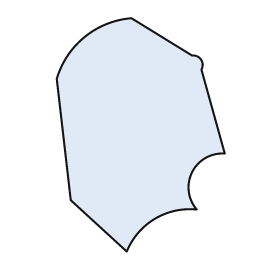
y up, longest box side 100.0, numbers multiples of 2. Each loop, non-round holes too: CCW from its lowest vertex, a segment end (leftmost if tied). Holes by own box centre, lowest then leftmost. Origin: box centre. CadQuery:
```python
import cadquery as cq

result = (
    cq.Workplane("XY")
    .moveTo(-6.0, -50.0)
    .threePointArc((6.0, -36.0), (24.0, -32.0))
    .threePointArc((22.0, -16.0), (36.0, -8.0))
    .lineTo(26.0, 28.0)
    .threePointArc((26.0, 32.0), (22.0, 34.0))
    .lineTo(-4.0, 50.0)
    .threePointArc((-24.0, 42.0), (-36.0, 24.0))
    .lineTo(-30.0, -28.0)
    .close()
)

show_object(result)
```